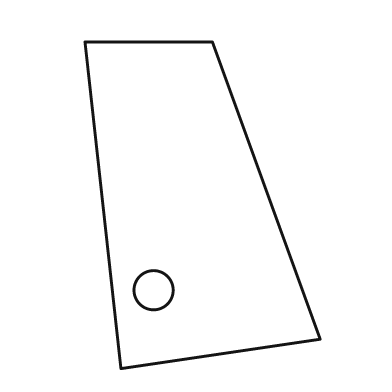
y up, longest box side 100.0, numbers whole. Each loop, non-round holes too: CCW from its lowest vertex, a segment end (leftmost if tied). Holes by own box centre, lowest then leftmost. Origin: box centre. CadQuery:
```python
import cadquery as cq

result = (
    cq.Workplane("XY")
    .moveTo(-25.0, -50.0)
    .lineTo(36.0, -41.0)
    .lineTo(3.0, 50.0)
    .lineTo(-36.0, 50.0)
    .close()
    .moveTo(-15.0, -26.0)
    .circle(6.0)
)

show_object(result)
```